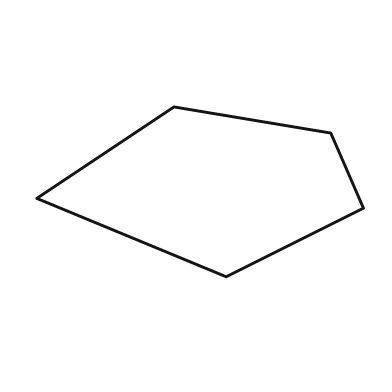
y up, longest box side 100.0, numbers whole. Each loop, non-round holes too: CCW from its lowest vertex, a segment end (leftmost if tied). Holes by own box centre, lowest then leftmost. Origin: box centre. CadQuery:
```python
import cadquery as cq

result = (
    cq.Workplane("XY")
    .moveTo(8.0, -26.0)
    .lineTo(50.0, -5.0)
    .lineTo(40.0, 18.0)
    .lineTo(-8.0, 26.0)
    .lineTo(-50.0, -2.0)
    .close()
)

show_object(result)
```